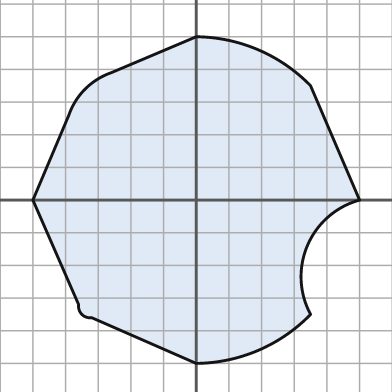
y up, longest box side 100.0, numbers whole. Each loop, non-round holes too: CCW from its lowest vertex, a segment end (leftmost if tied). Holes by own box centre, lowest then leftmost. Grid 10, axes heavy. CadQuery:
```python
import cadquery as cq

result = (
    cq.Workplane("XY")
    .moveTo(0.0, -50.0)
    .threePointArc((19.0, -46.0), (35.0, -35.0))
    .threePointArc((34.0, -14.0), (50.0, 0.0))
    .lineTo(35.0, 35.0)
    .threePointArc((19.0, 46.0), (0.0, 50.0))
    .lineTo(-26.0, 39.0)
    .threePointArc((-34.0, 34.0), (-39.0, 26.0))
    .lineTo(-50.0, 0.0)
    .lineTo(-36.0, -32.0)
    .threePointArc((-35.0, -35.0), (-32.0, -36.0))
    .close()
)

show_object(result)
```